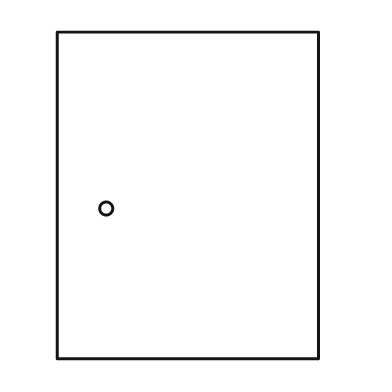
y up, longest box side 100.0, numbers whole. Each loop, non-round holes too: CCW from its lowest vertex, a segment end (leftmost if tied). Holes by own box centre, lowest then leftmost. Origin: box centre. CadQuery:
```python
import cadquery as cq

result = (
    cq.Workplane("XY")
    .moveTo(-40.0, -50.0)
    .lineTo(40.0, -50.0)
    .lineTo(40.0, 50.0)
    .lineTo(-40.0, 50.0)
    .close()
    .moveTo(-25.0, -4.0)
    .circle(2.0)
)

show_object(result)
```